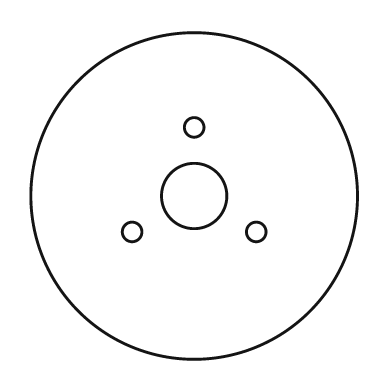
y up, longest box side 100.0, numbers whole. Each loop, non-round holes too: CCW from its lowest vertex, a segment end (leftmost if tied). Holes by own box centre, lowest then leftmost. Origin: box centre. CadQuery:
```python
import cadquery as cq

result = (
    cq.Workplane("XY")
    .moveTo(0.0, 0.0)
    .circle(50.0)
    .moveTo(-19.0, -11.0)
    .circle(3.0)
    .moveTo(19.0, -11.0)
    .circle(3.0)
    .moveTo(0.0, 0.0)
    .circle(10.0)
    .moveTo(0.0, 21.0)
    .circle(3.0)
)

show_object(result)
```